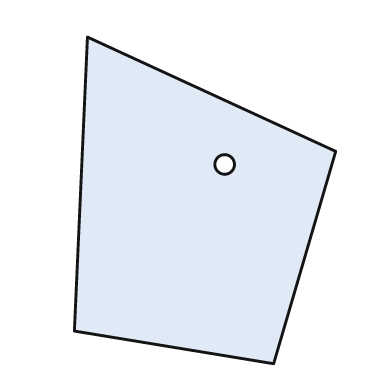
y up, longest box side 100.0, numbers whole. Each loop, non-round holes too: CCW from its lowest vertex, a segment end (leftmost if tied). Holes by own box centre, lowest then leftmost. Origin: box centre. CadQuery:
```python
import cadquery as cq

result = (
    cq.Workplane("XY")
    .moveTo(21.0, -50.0)
    .lineTo(40.0, 15.0)
    .lineTo(-36.0, 50.0)
    .lineTo(-40.0, -40.0)
    .close()
    .moveTo(6.0, 11.0)
    .circle(3.0)
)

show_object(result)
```